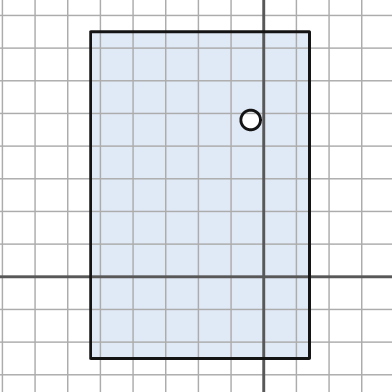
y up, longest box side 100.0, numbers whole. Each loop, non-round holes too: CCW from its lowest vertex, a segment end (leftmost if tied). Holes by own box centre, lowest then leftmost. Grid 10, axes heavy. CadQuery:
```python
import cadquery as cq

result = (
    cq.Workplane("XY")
    .moveTo(-53.0, -25.0)
    .lineTo(14.0, -25.0)
    .lineTo(14.0, 75.0)
    .lineTo(-53.0, 75.0)
    .close()
    .moveTo(-4.0, 48.0)
    .circle(3.0)
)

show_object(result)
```